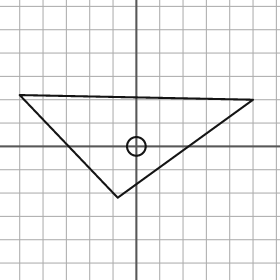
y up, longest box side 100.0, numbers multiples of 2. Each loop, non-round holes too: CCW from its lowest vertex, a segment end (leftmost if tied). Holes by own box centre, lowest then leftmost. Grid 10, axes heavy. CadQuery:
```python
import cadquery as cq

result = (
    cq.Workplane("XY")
    .moveTo(-8.0, -22.0)
    .lineTo(50.0, 20.0)
    .lineTo(-50.0, 22.0)
    .close()
    .moveTo(0.0, 0.0)
    .circle(4.0)
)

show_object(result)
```